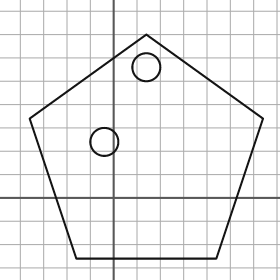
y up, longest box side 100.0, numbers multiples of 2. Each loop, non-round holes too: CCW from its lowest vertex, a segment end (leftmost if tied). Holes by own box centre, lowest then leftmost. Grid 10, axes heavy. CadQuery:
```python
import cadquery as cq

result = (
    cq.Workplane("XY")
    .moveTo(-16.0, -26.0)
    .lineTo(44.0, -26.0)
    .lineTo(64.0, 34.0)
    .lineTo(14.0, 70.0)
    .lineTo(-36.0, 34.0)
    .close()
    .moveTo(-4.0, 24.0)
    .circle(6.0)
    .moveTo(14.0, 56.0)
    .circle(6.0)
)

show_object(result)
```